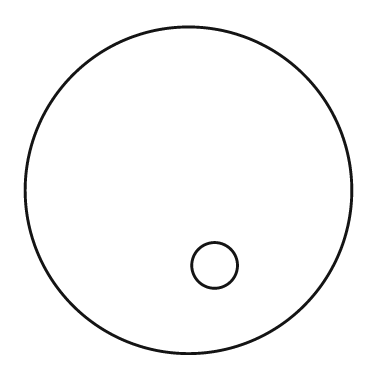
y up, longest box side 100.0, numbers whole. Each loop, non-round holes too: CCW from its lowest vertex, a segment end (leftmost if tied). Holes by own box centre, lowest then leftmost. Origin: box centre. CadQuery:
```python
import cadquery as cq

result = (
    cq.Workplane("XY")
    .moveTo(0.0, 0.0)
    .circle(50.0)
    .moveTo(8.0, -23.0)
    .circle(7.0)
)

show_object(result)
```